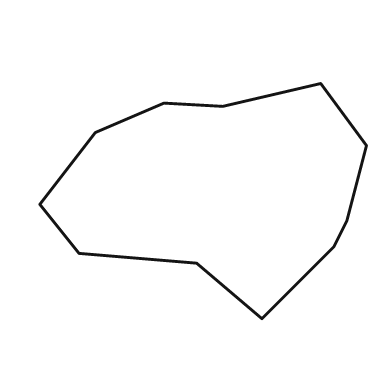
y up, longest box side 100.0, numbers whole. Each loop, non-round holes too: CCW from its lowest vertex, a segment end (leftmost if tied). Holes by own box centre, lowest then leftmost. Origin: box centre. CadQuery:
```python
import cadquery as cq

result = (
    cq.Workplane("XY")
    .moveTo(18.0, -36.0)
    .lineTo(40.0, -14.0)
    .lineTo(44.0, -6.0)
    .lineTo(50.0, 17.0)
    .lineTo(36.0, 36.0)
    .lineTo(6.0, 29.0)
    .lineTo(-12.0, 30.0)
    .lineTo(-33.0, 21.0)
    .lineTo(-50.0, -1.0)
    .lineTo(-38.0, -16.0)
    .lineTo(-2.0, -19.0)
    .close()
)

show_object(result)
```